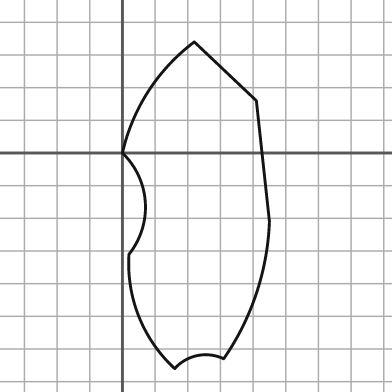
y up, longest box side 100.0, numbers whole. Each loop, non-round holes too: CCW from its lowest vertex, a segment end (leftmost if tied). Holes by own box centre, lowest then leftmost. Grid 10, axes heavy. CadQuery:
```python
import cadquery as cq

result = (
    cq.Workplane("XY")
    .moveTo(16.0, -66.0)
    .threePointArc((23.0, -62.0), (31.0, -63.0))
    .threePointArc((41.0, -43.0), (45.0, -21.0))
    .lineTo(41.0, 16.0)
    .lineTo(22.0, 34.0)
    .threePointArc((8.0, 19.0), (0.0, 0.0))
    .threePointArc((7.0, -15.0), (2.0, -31.0))
    .threePointArc((5.0, -50.0), (16.0, -66.0))
    .close()
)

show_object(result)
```